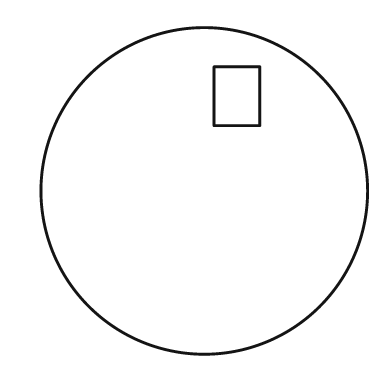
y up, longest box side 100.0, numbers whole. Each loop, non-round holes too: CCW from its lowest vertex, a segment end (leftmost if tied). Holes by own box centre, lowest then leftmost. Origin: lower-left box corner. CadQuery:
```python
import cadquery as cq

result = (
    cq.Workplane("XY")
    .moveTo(50.0, 50.0)
    .circle(50.0)
    .moveTo(53.0, 70.0)
    .lineTo(67.0, 70.0)
    .lineTo(67.0, 88.0)
    .lineTo(53.0, 88.0)
    .close()
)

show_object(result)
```